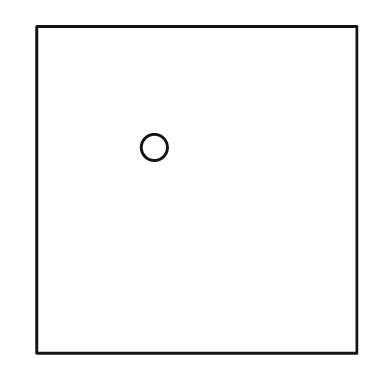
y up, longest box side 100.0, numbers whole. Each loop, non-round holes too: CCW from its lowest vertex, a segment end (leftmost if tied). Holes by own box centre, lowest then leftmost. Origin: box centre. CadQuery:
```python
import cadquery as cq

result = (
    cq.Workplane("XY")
    .moveTo(-49.0, -50.0)
    .lineTo(49.0, -50.0)
    .lineTo(49.0, 50.0)
    .lineTo(-49.0, 50.0)
    .close()
    .moveTo(-13.0, 13.0)
    .circle(4.0)
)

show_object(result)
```